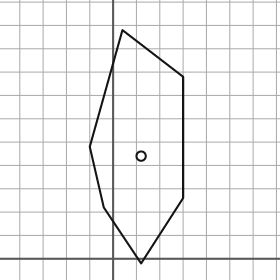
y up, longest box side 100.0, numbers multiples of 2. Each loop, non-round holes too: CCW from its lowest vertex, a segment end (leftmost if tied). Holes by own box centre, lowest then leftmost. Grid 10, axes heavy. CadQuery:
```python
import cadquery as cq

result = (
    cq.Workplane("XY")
    .moveTo(12.0, -2.0)
    .lineTo(30.0, 26.0)
    .lineTo(30.0, 78.0)
    .lineTo(4.0, 98.0)
    .lineTo(-10.0, 48.0)
    .lineTo(-4.0, 22.0)
    .close()
    .moveTo(12.0, 44.0)
    .circle(2.0)
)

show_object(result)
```